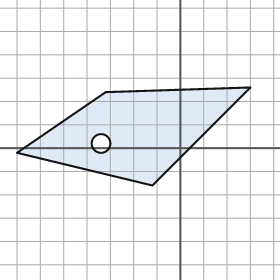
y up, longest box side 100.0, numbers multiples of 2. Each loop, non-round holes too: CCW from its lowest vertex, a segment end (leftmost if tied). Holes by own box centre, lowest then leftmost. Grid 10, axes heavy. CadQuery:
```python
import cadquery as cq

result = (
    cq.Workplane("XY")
    .moveTo(-12.0, -16.0)
    .lineTo(30.0, 26.0)
    .lineTo(-32.0, 24.0)
    .lineTo(-70.0, -2.0)
    .close()
    .moveTo(-34.0, 2.0)
    .circle(4.0)
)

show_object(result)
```